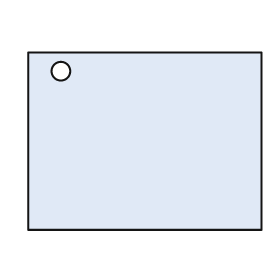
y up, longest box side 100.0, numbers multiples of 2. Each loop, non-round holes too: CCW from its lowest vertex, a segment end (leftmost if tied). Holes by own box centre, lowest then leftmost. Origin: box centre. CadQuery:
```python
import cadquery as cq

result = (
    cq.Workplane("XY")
    .moveTo(-50.0, -38.0)
    .lineTo(50.0, -38.0)
    .lineTo(50.0, 38.0)
    .lineTo(-50.0, 38.0)
    .close()
    .moveTo(-36.0, 30.0)
    .circle(4.0)
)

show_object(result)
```